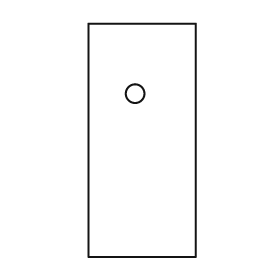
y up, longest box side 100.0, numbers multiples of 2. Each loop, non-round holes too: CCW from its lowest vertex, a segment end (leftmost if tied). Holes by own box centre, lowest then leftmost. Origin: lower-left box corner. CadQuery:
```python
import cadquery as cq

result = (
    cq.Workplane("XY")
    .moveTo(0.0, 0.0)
    .lineTo(46.0, 0.0)
    .lineTo(46.0, 100.0)
    .lineTo(0.0, 100.0)
    .close()
    .moveTo(20.0, 70.0)
    .circle(4.0)
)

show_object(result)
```